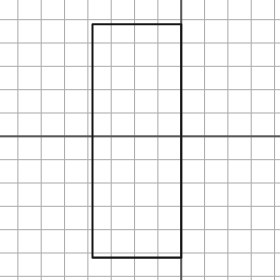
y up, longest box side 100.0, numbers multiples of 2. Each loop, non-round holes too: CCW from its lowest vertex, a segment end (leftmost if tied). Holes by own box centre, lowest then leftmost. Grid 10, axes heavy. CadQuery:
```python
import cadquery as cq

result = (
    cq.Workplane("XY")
    .moveTo(-38.0, -52.0)
    .lineTo(0.0, -52.0)
    .lineTo(0.0, 48.0)
    .lineTo(-38.0, 48.0)
    .close()
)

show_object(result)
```